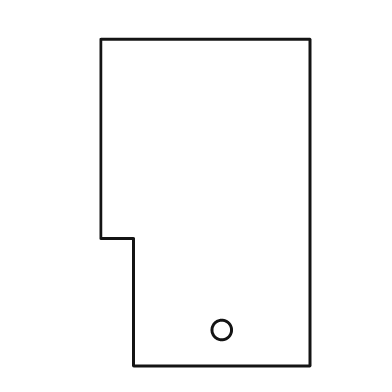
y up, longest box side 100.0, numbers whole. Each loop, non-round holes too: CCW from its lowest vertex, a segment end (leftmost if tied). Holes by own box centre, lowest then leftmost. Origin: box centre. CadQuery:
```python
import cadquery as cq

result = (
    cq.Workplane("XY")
    .moveTo(-22.0, -50.0)
    .lineTo(32.0, -50.0)
    .lineTo(32.0, 50.0)
    .lineTo(-32.0, 50.0)
    .lineTo(-32.0, -11.0)
    .lineTo(-22.0, -11.0)
    .close()
    .moveTo(5.0, -39.0)
    .circle(3.0)
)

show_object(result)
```